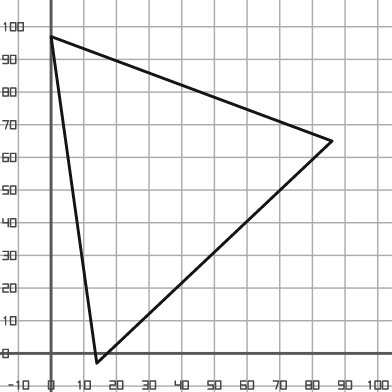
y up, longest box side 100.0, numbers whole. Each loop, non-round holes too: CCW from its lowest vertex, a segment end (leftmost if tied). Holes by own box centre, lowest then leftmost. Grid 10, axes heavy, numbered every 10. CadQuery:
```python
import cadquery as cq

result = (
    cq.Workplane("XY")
    .moveTo(14.0, -3.0)
    .lineTo(86.0, 65.0)
    .lineTo(0.0, 97.0)
    .close()
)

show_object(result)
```